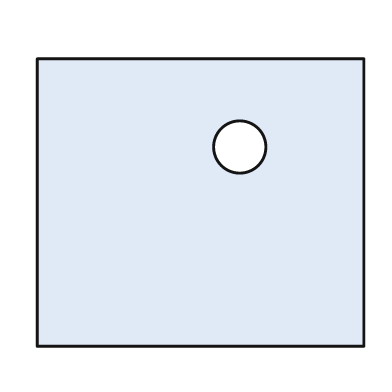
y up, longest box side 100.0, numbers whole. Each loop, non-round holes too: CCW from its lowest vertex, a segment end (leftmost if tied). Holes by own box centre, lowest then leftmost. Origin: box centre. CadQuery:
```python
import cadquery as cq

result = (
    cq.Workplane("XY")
    .moveTo(-50.0, -44.0)
    .lineTo(50.0, -44.0)
    .lineTo(50.0, 44.0)
    .lineTo(-50.0, 44.0)
    .close()
    .moveTo(12.0, 17.0)
    .circle(8.0)
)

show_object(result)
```